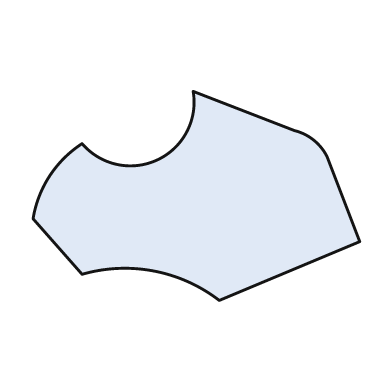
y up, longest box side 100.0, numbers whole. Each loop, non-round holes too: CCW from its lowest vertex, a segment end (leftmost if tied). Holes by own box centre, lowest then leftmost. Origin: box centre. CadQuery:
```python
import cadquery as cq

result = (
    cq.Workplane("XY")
    .moveTo(7.0, -32.0)
    .lineTo(50.0, -14.0)
    .lineTo(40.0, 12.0)
    .threePointArc((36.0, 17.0), (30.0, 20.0))
    .lineTo(-1.0, 32.0)
    .threePointArc((-12.0, 11.0), (-35.0, 16.0))
    .threePointArc((-45.0, 6.0), (-50.0, -7.0))
    .lineTo(-35.0, -24.0)
    .threePointArc((-13.0, -23.0), (7.0, -32.0))
    .close()
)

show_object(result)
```